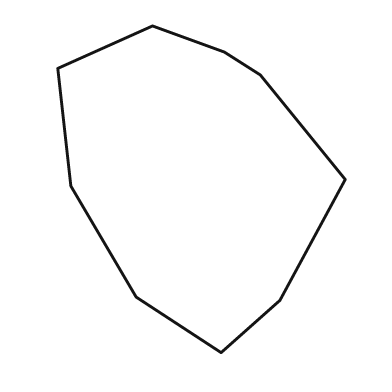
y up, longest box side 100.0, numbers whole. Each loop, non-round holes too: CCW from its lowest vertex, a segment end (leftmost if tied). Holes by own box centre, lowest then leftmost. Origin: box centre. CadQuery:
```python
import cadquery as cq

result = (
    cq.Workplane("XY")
    .moveTo(6.0, -50.0)
    .lineTo(24.0, -34.0)
    .lineTo(44.0, 3.0)
    .lineTo(18.0, 35.0)
    .lineTo(7.0, 42.0)
    .lineTo(-15.0, 50.0)
    .lineTo(-44.0, 37.0)
    .lineTo(-40.0, 1.0)
    .lineTo(-20.0, -33.0)
    .close()
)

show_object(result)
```